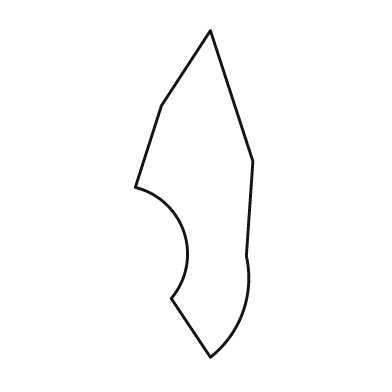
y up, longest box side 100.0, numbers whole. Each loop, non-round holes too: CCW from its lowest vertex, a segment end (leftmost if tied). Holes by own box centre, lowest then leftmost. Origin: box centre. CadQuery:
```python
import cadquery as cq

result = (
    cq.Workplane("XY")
    .moveTo(5.0, -50.0)
    .threePointArc((15.0, -36.0), (16.0, -19.0))
    .lineTo(18.0, 10.0)
    .lineTo(5.0, 50.0)
    .lineTo(-10.0, 27.0)
    .lineTo(-18.0, 2.0)
    .threePointArc((-3.0, -12.0), (-7.0, -32.0))
    .close()
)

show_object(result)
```